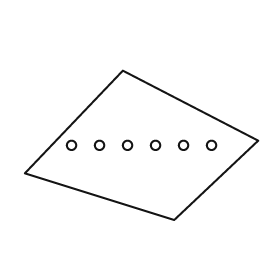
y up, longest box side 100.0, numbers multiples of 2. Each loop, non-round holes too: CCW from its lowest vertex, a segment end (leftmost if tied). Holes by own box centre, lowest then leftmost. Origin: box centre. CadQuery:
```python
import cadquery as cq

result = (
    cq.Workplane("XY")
    .moveTo(14.0, -32.0)
    .lineTo(50.0, 2.0)
    .lineTo(-8.0, 32.0)
    .lineTo(-50.0, -12.0)
    .close()
    .moveTo(-30.0, 0.0)
    .circle(2.0)
    .moveTo(-18.0, 0.0)
    .circle(2.0)
    .moveTo(-6.0, 0.0)
    .circle(2.0)
    .moveTo(6.0, 0.0)
    .circle(2.0)
    .moveTo(18.0, 0.0)
    .circle(2.0)
    .moveTo(30.0, 0.0)
    .circle(2.0)
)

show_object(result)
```